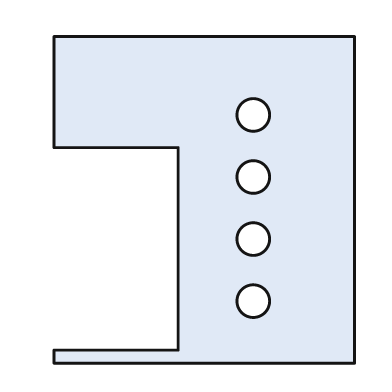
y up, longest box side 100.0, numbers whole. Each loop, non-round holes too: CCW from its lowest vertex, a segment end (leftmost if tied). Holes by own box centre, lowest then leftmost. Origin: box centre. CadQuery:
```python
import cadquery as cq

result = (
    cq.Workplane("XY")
    .moveTo(-46.0, -50.0)
    .lineTo(46.0, -50.0)
    .lineTo(46.0, 50.0)
    .lineTo(-46.0, 50.0)
    .lineTo(-46.0, 16.0)
    .lineTo(-8.0, 16.0)
    .lineTo(-8.0, -46.0)
    .lineTo(-46.0, -46.0)
    .close()
    .moveTo(15.0, -31.0)
    .circle(5.0)
    .moveTo(15.0, -12.0)
    .circle(5.0)
    .moveTo(15.0, 7.0)
    .circle(5.0)
    .moveTo(15.0, 26.0)
    .circle(5.0)
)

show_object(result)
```